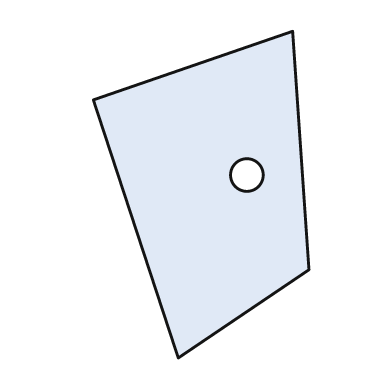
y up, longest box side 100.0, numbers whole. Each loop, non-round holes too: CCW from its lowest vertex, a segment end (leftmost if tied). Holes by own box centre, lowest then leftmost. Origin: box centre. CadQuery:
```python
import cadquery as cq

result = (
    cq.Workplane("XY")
    .moveTo(-7.0, -50.0)
    .lineTo(33.0, -23.0)
    .lineTo(28.0, 50.0)
    .lineTo(-33.0, 29.0)
    .close()
    .moveTo(14.0, 6.0)
    .circle(5.0)
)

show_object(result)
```